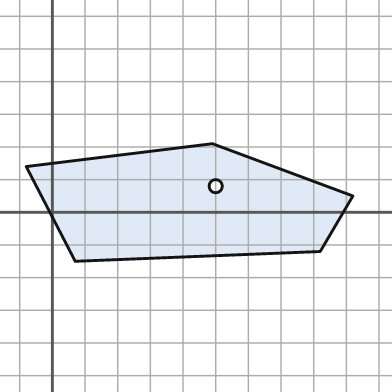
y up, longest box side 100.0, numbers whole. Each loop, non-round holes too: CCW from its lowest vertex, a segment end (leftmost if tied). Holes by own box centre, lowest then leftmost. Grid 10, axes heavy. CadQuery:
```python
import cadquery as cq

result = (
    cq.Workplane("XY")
    .moveTo(7.0, -15.0)
    .lineTo(82.0, -12.0)
    .lineTo(92.0, 5.0)
    .lineTo(49.0, 21.0)
    .lineTo(-8.0, 14.0)
    .close()
    .moveTo(50.0, 8.0)
    .circle(2.0)
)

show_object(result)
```